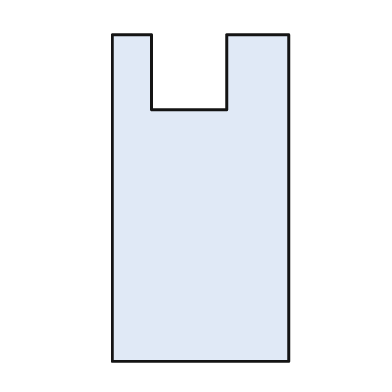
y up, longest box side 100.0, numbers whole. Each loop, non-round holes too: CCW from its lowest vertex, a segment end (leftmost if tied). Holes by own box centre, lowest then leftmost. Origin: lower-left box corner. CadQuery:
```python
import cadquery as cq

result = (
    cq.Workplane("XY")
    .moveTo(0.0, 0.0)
    .lineTo(54.0, 0.0)
    .lineTo(54.0, 100.0)
    .lineTo(35.0, 100.0)
    .lineTo(35.0, 77.0)
    .lineTo(12.0, 77.0)
    .lineTo(12.0, 100.0)
    .lineTo(0.0, 100.0)
    .close()
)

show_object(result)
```